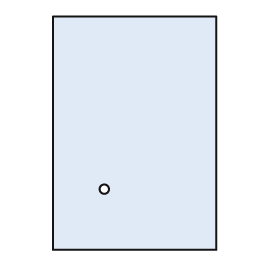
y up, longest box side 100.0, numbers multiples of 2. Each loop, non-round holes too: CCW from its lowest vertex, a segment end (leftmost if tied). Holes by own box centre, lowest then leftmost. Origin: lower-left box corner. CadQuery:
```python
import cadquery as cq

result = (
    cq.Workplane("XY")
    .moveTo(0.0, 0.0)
    .lineTo(70.0, 0.0)
    .lineTo(70.0, 100.0)
    .lineTo(0.0, 100.0)
    .close()
    .moveTo(22.0, 26.0)
    .circle(2.0)
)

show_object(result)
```